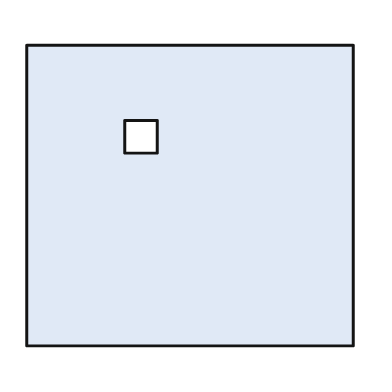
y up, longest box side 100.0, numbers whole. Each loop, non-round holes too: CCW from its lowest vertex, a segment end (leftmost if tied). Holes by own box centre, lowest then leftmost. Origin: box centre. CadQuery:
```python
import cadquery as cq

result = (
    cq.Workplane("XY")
    .moveTo(-50.0, -46.0)
    .lineTo(50.0, -46.0)
    .lineTo(50.0, 46.0)
    .lineTo(-50.0, 46.0)
    .close()
    .moveTo(-20.0, 13.0)
    .lineTo(-10.0, 13.0)
    .lineTo(-10.0, 23.0)
    .lineTo(-20.0, 23.0)
    .close()
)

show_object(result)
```